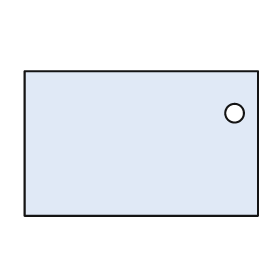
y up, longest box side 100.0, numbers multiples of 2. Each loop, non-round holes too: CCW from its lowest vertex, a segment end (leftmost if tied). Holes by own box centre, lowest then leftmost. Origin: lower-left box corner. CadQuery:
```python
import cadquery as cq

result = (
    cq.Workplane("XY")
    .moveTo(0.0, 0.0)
    .lineTo(100.0, 0.0)
    .lineTo(100.0, 62.0)
    .lineTo(0.0, 62.0)
    .close()
    .moveTo(90.0, 44.0)
    .circle(4.0)
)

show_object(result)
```